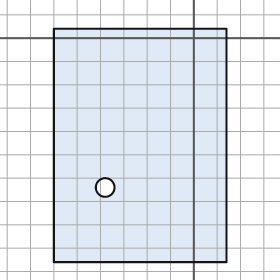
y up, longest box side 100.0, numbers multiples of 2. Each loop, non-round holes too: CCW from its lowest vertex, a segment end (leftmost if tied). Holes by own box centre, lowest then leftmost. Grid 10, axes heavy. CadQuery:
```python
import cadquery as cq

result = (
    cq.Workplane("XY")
    .moveTo(-60.0, -96.0)
    .lineTo(14.0, -96.0)
    .lineTo(14.0, 4.0)
    .lineTo(-60.0, 4.0)
    .close()
    .moveTo(-38.0, -64.0)
    .circle(4.0)
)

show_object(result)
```